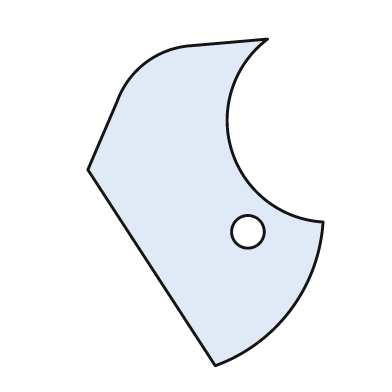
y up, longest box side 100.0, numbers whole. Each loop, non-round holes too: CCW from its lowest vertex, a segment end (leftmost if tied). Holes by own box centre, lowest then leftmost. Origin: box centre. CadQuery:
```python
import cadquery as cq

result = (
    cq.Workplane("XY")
    .moveTo(3.0, -50.0)
    .threePointArc((26.0, -33.0), (36.0, -6.0))
    .threePointArc((8.0, 16.0), (19.0, 50.0))
    .lineTo(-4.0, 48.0)
    .threePointArc((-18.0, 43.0), (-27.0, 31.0))
    .lineTo(-36.0, 10.0)
    .close()
    .moveTo(13.0, -9.0)
    .circle(5.0)
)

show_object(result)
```